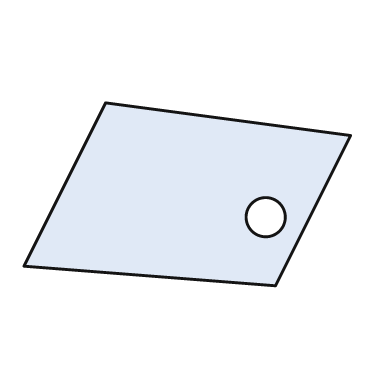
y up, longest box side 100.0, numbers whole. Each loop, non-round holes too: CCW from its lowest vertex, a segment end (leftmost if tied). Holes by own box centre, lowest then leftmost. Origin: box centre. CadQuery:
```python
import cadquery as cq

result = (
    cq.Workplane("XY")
    .moveTo(27.0, -28.0)
    .lineTo(50.0, 18.0)
    .lineTo(-25.0, 28.0)
    .lineTo(-50.0, -22.0)
    .close()
    .moveTo(24.0, -7.0)
    .circle(6.0)
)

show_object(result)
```